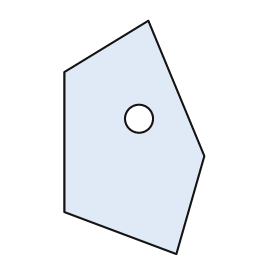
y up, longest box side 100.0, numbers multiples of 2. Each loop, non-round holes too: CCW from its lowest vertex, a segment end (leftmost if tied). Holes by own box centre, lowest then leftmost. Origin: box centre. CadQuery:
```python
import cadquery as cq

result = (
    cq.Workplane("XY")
    .moveTo(18.0, -50.0)
    .lineTo(30.0, -8.0)
    .lineTo(6.0, 50.0)
    .lineTo(-30.0, 28.0)
    .lineTo(-30.0, -32.0)
    .close()
    .moveTo(2.0, 8.0)
    .circle(6.0)
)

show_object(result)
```